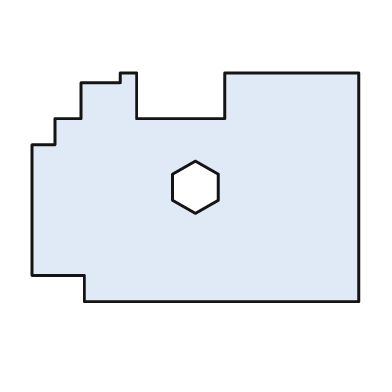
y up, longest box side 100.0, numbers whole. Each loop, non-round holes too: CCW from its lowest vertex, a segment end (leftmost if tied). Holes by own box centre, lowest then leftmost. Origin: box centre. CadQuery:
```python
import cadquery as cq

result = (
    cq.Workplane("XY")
    .moveTo(-34.0, -35.0)
    .lineTo(50.0, -35.0)
    .lineTo(50.0, 35.0)
    .lineTo(9.0, 35.0)
    .lineTo(9.0, 21.0)
    .lineTo(-18.0, 21.0)
    .lineTo(-18.0, 35.0)
    .lineTo(-23.0, 35.0)
    .lineTo(-23.0, 32.0)
    .lineTo(-35.0, 32.0)
    .lineTo(-35.0, 21.0)
    .lineTo(-43.0, 21.0)
    .lineTo(-43.0, 13.0)
    .lineTo(-50.0, 13.0)
    .lineTo(-50.0, -27.0)
    .lineTo(-34.0, -27.0)
    .close()
    .moveTo(0.0, -8.0)
    .lineTo(7.0, -4.0)
    .lineTo(7.0, 4.0)
    .lineTo(0.0, 8.0)
    .lineTo(-7.0, 4.0)
    .lineTo(-7.0, -4.0)
    .close()
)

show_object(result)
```